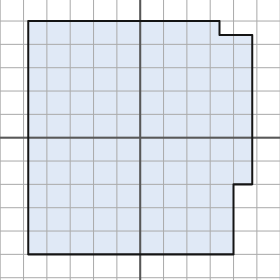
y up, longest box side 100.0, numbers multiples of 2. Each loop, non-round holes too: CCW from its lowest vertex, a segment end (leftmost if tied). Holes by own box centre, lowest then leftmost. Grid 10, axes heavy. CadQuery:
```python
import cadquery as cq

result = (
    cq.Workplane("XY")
    .moveTo(-48.0, -50.0)
    .lineTo(40.0, -50.0)
    .lineTo(40.0, -20.0)
    .lineTo(48.0, -20.0)
    .lineTo(48.0, 44.0)
    .lineTo(34.0, 44.0)
    .lineTo(34.0, 50.0)
    .lineTo(-48.0, 50.0)
    .close()
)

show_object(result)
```